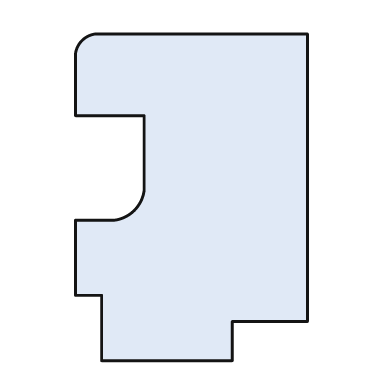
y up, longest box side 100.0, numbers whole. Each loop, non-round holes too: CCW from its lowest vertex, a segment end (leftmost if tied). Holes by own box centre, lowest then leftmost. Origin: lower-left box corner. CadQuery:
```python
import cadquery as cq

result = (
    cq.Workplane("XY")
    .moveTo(8.0, 0.0)
    .lineTo(48.0, 0.0)
    .lineTo(48.0, 12.0)
    .lineTo(71.0, 12.0)
    .lineTo(71.0, 100.0)
    .lineTo(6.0, 100.0)
    .threePointArc((2.0, 98.0), (0.0, 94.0))
    .lineTo(0.0, 75.0)
    .lineTo(21.0, 75.0)
    .lineTo(21.0, 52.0)
    .threePointArc((18.0, 46.0), (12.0, 43.0))
    .lineTo(0.0, 43.0)
    .lineTo(0.0, 20.0)
    .lineTo(8.0, 20.0)
    .close()
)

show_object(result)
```